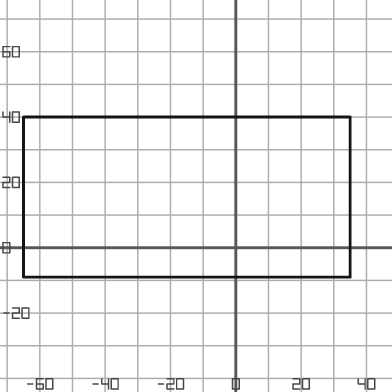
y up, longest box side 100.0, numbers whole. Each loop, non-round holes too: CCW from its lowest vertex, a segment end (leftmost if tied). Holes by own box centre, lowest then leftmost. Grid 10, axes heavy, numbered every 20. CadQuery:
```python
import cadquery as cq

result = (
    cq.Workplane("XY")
    .moveTo(-65.0, -9.0)
    .lineTo(35.0, -9.0)
    .lineTo(35.0, 40.0)
    .lineTo(-65.0, 40.0)
    .close()
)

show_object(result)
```